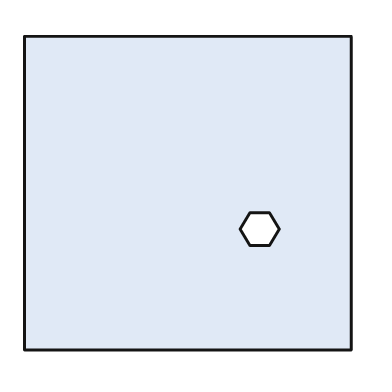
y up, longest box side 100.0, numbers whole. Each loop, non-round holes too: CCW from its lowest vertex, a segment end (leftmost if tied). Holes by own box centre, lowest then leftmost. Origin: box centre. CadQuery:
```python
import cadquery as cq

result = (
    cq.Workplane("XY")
    .moveTo(-50.0, -48.0)
    .lineTo(50.0, -48.0)
    .lineTo(50.0, 48.0)
    .lineTo(-50.0, 48.0)
    .close()
    .moveTo(19.0, -16.0)
    .lineTo(25.0, -16.0)
    .lineTo(28.0, -11.0)
    .lineTo(25.0, -6.0)
    .lineTo(19.0, -6.0)
    .lineTo(16.0, -11.0)
    .close()
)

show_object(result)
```